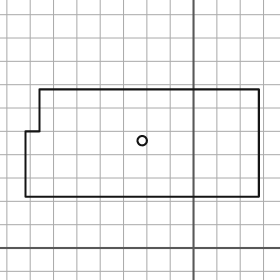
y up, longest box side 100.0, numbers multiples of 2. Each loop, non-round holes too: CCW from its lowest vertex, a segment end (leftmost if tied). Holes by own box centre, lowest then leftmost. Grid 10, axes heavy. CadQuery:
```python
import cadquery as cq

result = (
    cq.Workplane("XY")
    .moveTo(-72.0, 22.0)
    .lineTo(28.0, 22.0)
    .lineTo(28.0, 68.0)
    .lineTo(-66.0, 68.0)
    .lineTo(-66.0, 50.0)
    .lineTo(-72.0, 50.0)
    .close()
    .moveTo(-22.0, 46.0)
    .circle(2.0)
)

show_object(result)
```